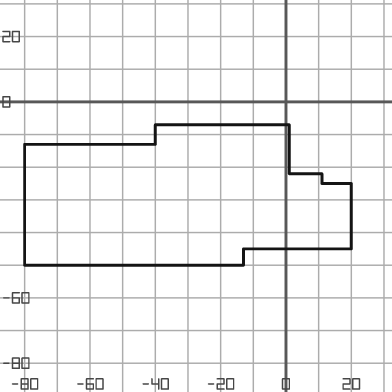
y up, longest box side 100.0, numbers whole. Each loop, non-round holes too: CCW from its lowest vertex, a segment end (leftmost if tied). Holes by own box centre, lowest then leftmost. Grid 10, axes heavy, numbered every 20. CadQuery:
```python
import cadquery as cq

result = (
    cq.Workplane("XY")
    .moveTo(-80.0, -50.0)
    .lineTo(-13.0, -50.0)
    .lineTo(-13.0, -45.0)
    .lineTo(20.0, -45.0)
    .lineTo(20.0, -25.0)
    .lineTo(11.0, -25.0)
    .lineTo(11.0, -22.0)
    .lineTo(1.0, -22.0)
    .lineTo(1.0, -7.0)
    .lineTo(-40.0, -7.0)
    .lineTo(-40.0, -13.0)
    .lineTo(-80.0, -13.0)
    .close()
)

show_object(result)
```